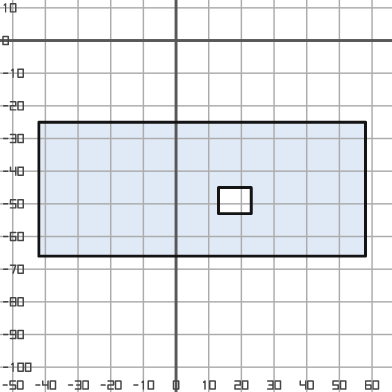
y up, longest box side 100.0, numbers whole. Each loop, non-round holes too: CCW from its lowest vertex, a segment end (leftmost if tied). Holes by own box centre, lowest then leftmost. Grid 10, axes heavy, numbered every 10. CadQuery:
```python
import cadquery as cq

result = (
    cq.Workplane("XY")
    .moveTo(-42.0, -66.0)
    .lineTo(58.0, -66.0)
    .lineTo(58.0, -25.0)
    .lineTo(-42.0, -25.0)
    .close()
    .moveTo(13.0, -53.0)
    .lineTo(23.0, -53.0)
    .lineTo(23.0, -45.0)
    .lineTo(13.0, -45.0)
    .close()
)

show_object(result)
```